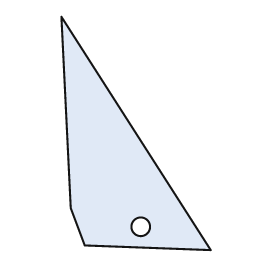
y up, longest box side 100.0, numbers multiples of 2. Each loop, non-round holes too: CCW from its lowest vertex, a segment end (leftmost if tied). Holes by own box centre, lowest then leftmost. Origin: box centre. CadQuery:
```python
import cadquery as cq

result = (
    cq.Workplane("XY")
    .moveTo(32.0, -50.0)
    .lineTo(-32.0, 50.0)
    .lineTo(-28.0, -32.0)
    .lineTo(-22.0, -48.0)
    .close()
    .moveTo(2.0, -40.0)
    .circle(4.0)
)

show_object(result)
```